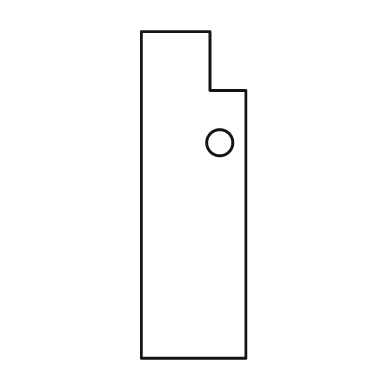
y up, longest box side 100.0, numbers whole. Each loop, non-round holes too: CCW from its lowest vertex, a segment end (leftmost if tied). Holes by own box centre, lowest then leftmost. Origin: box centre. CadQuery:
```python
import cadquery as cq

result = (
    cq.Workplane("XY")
    .moveTo(-16.0, -50.0)
    .lineTo(16.0, -50.0)
    .lineTo(16.0, 32.0)
    .lineTo(5.0, 32.0)
    .lineTo(5.0, 50.0)
    .lineTo(-16.0, 50.0)
    .close()
    .moveTo(8.0, 16.0)
    .circle(4.0)
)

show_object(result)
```